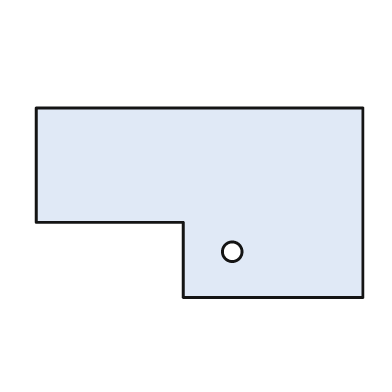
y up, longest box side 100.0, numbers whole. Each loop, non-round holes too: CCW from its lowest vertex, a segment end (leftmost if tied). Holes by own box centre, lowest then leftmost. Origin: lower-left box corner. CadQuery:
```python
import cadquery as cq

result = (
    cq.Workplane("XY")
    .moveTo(45.0, 0.0)
    .lineTo(100.0, 0.0)
    .lineTo(100.0, 58.0)
    .lineTo(0.0, 58.0)
    .lineTo(0.0, 23.0)
    .lineTo(45.0, 23.0)
    .close()
    .moveTo(60.0, 14.0)
    .circle(3.0)
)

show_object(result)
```